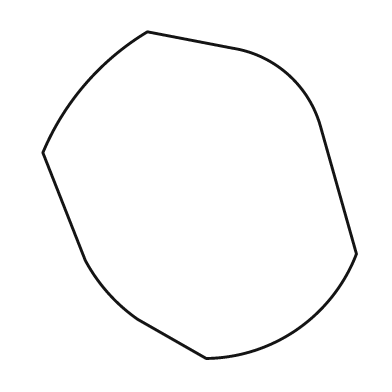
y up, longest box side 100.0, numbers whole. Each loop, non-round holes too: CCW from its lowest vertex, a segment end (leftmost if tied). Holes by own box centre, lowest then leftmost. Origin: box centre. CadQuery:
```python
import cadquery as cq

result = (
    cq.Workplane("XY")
    .moveTo(2.0, -50.0)
    .threePointArc((30.0, -41.0), (48.0, -18.0))
    .lineTo(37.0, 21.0)
    .threePointArc((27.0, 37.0), (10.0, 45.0))
    .lineTo(-16.0, 50.0)
    .threePointArc((-35.0, 34.0), (-48.0, 13.0))
    .lineTo(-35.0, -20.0)
    .threePointArc((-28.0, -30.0), (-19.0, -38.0))
    .close()
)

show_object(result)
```